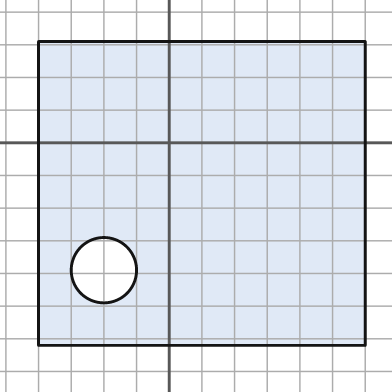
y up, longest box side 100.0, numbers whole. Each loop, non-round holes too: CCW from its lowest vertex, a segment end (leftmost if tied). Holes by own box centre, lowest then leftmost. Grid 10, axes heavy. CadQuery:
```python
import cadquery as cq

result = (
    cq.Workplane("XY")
    .moveTo(-40.0, -62.0)
    .lineTo(60.0, -62.0)
    .lineTo(60.0, 31.0)
    .lineTo(-40.0, 31.0)
    .close()
    .moveTo(-20.0, -39.0)
    .circle(10.0)
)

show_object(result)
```